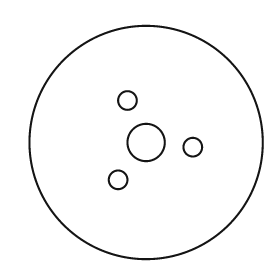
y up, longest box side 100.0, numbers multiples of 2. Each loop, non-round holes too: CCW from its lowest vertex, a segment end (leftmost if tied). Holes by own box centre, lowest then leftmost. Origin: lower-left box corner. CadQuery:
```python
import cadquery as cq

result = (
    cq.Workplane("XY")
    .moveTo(50.0, 50.0)
    .circle(50.0)
    .moveTo(38.0, 34.0)
    .circle(4.0)
    .moveTo(70.0, 48.0)
    .circle(4.0)
    .moveTo(50.0, 50.0)
    .circle(8.0)
    .moveTo(42.0, 68.0)
    .circle(4.0)
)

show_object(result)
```